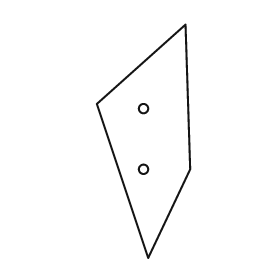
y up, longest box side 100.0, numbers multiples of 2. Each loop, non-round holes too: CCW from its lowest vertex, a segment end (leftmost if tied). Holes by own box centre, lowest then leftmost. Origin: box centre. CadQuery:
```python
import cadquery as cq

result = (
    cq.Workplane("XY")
    .moveTo(2.0, -50.0)
    .lineTo(20.0, -12.0)
    .lineTo(18.0, 50.0)
    .lineTo(-20.0, 16.0)
    .close()
    .moveTo(0.0, -12.0)
    .circle(2.0)
    .moveTo(0.0, 14.0)
    .circle(2.0)
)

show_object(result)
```